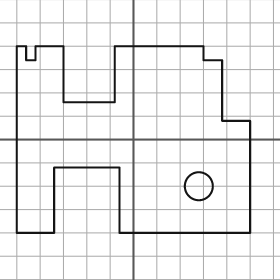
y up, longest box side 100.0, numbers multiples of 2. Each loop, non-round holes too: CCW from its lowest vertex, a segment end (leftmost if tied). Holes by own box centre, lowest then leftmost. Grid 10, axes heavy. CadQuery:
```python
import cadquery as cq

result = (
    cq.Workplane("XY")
    .moveTo(-50.0, -40.0)
    .lineTo(-34.0, -40.0)
    .lineTo(-34.0, -12.0)
    .lineTo(-6.0, -12.0)
    .lineTo(-6.0, -40.0)
    .lineTo(50.0, -40.0)
    .lineTo(50.0, 8.0)
    .lineTo(38.0, 8.0)
    .lineTo(38.0, 34.0)
    .lineTo(30.0, 34.0)
    .lineTo(30.0, 40.0)
    .lineTo(-8.0, 40.0)
    .lineTo(-8.0, 16.0)
    .lineTo(-30.0, 16.0)
    .lineTo(-30.0, 40.0)
    .lineTo(-42.0, 40.0)
    .lineTo(-42.0, 34.0)
    .lineTo(-46.0, 34.0)
    .lineTo(-46.0, 40.0)
    .lineTo(-50.0, 40.0)
    .close()
    .moveTo(28.0, -20.0)
    .circle(6.0)
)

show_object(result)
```